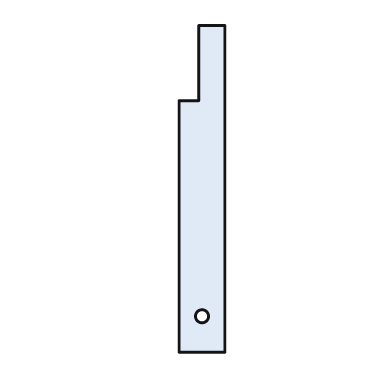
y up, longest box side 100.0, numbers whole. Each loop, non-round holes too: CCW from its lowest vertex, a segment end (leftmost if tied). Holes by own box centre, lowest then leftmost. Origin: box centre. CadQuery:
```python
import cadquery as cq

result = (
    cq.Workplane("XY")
    .moveTo(-7.0, -50.0)
    .lineTo(7.0, -50.0)
    .lineTo(7.0, 50.0)
    .lineTo(-1.0, 50.0)
    .lineTo(-1.0, 27.0)
    .lineTo(-7.0, 27.0)
    .close()
    .moveTo(0.0, -39.0)
    .circle(2.0)
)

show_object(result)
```